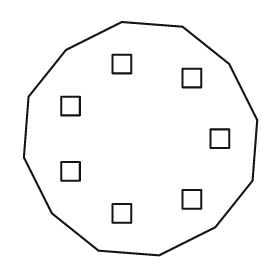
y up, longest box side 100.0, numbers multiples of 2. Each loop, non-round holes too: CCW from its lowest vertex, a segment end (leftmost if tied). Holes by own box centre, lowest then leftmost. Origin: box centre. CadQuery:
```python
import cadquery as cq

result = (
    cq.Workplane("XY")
    .moveTo(8.0, -50.0)
    .lineTo(32.0, -38.0)
    .lineTo(48.0, -18.0)
    .lineTo(50.0, 8.0)
    .lineTo(38.0, 32.0)
    .lineTo(18.0, 48.0)
    .lineTo(-8.0, 50.0)
    .lineTo(-32.0, 38.0)
    .lineTo(-48.0, 18.0)
    .lineTo(-50.0, -8.0)
    .lineTo(-38.0, -32.0)
    .lineTo(-18.0, -48.0)
    .close()
    .moveTo(-12.0, -36.0)
    .lineTo(-4.0, -36.0)
    .lineTo(-4.0, -28.0)
    .lineTo(-12.0, -28.0)
    .close()
    .moveTo(18.0, -30.0)
    .lineTo(26.0, -30.0)
    .lineTo(26.0, -22.0)
    .lineTo(18.0, -22.0)
    .close()
    .moveTo(-34.0, -18.0)
    .lineTo(-26.0, -18.0)
    .lineTo(-26.0, -10.0)
    .lineTo(-34.0, -10.0)
    .close()
    .moveTo(30.0, -4.0)
    .lineTo(38.0, -4.0)
    .lineTo(38.0, 4.0)
    .lineTo(30.0, 4.0)
    .close()
    .moveTo(-34.0, 10.0)
    .lineTo(-26.0, 10.0)
    .lineTo(-26.0, 18.0)
    .lineTo(-34.0, 18.0)
    .close()
    .moveTo(18.0, 22.0)
    .lineTo(26.0, 22.0)
    .lineTo(26.0, 30.0)
    .lineTo(18.0, 30.0)
    .close()
    .moveTo(-12.0, 28.0)
    .lineTo(-4.0, 28.0)
    .lineTo(-4.0, 36.0)
    .lineTo(-12.0, 36.0)
    .close()
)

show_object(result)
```